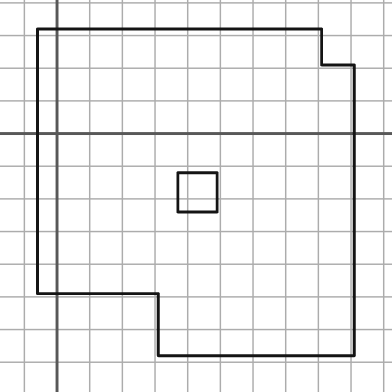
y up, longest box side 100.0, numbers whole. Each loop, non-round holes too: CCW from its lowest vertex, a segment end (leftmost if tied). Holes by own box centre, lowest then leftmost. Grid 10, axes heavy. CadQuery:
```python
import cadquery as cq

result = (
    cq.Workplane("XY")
    .moveTo(31.0, -68.0)
    .lineTo(91.0, -68.0)
    .lineTo(91.0, 21.0)
    .lineTo(81.0, 21.0)
    .lineTo(81.0, 32.0)
    .lineTo(-6.0, 32.0)
    .lineTo(-6.0, -49.0)
    .lineTo(31.0, -49.0)
    .close()
    .moveTo(37.0, -24.0)
    .lineTo(49.0, -24.0)
    .lineTo(49.0, -12.0)
    .lineTo(37.0, -12.0)
    .close()
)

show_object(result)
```